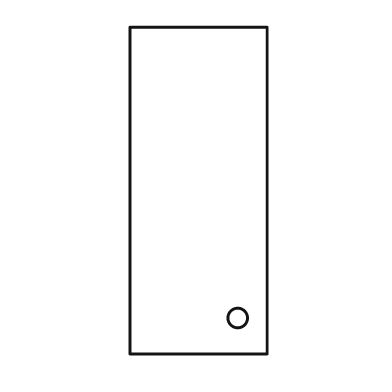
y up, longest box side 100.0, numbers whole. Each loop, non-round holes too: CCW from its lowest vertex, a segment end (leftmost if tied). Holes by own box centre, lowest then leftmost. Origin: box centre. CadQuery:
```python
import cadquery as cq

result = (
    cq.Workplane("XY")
    .moveTo(-21.0, -50.0)
    .lineTo(21.0, -50.0)
    .lineTo(21.0, 50.0)
    .lineTo(-21.0, 50.0)
    .close()
    .moveTo(12.0, -39.0)
    .circle(3.0)
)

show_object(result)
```